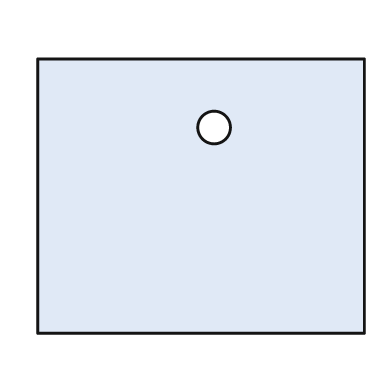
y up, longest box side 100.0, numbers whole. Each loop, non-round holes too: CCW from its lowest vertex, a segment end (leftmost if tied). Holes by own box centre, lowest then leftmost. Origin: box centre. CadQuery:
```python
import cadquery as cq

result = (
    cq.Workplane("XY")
    .moveTo(-50.0, -42.0)
    .lineTo(50.0, -42.0)
    .lineTo(50.0, 42.0)
    .lineTo(-50.0, 42.0)
    .close()
    .moveTo(4.0, 21.0)
    .circle(5.0)
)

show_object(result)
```